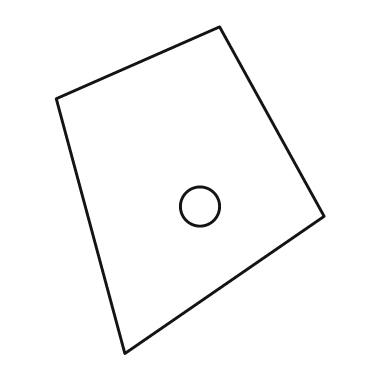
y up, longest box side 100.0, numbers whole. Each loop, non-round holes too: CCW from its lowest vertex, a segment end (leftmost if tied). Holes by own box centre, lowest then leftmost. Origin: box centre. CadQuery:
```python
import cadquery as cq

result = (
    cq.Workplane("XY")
    .moveTo(-20.0, -50.0)
    .lineTo(41.0, -8.0)
    .lineTo(9.0, 50.0)
    .lineTo(-41.0, 28.0)
    .close()
    .moveTo(3.0, -5.0)
    .circle(6.0)
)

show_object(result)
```